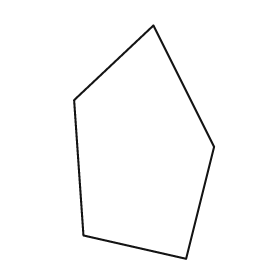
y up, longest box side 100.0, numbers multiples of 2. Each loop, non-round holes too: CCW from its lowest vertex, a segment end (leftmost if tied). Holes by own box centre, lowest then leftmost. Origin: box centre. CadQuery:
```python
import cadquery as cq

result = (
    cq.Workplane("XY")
    .moveTo(18.0, -50.0)
    .lineTo(30.0, -2.0)
    .lineTo(4.0, 50.0)
    .lineTo(-30.0, 18.0)
    .lineTo(-26.0, -40.0)
    .close()
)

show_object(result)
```